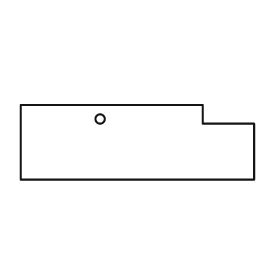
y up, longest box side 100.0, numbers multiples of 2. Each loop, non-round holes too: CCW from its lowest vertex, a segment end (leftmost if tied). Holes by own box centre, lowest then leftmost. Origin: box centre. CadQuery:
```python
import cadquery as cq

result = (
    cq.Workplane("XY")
    .moveTo(-50.0, -16.0)
    .lineTo(50.0, -16.0)
    .lineTo(50.0, 8.0)
    .lineTo(28.0, 8.0)
    .lineTo(28.0, 16.0)
    .lineTo(-50.0, 16.0)
    .close()
    .moveTo(-16.0, 10.0)
    .circle(2.0)
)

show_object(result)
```